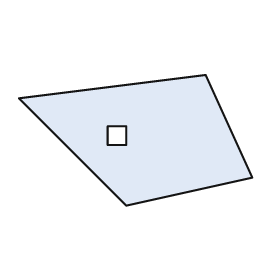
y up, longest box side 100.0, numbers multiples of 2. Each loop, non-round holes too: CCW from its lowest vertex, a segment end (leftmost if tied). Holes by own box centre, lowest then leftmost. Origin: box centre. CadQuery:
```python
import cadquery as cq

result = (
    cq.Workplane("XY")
    .moveTo(-4.0, -28.0)
    .lineTo(50.0, -16.0)
    .lineTo(30.0, 28.0)
    .lineTo(-50.0, 18.0)
    .close()
    .moveTo(-12.0, -2.0)
    .lineTo(-4.0, -2.0)
    .lineTo(-4.0, 6.0)
    .lineTo(-12.0, 6.0)
    .close()
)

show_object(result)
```